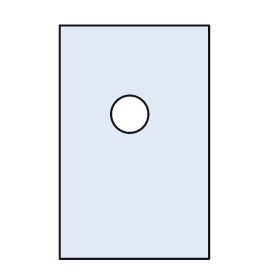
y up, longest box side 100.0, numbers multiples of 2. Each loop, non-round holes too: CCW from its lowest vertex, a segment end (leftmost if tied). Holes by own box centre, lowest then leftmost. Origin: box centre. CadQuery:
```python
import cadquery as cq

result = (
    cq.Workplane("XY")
    .moveTo(-32.0, -50.0)
    .lineTo(32.0, -50.0)
    .lineTo(32.0, 50.0)
    .lineTo(-32.0, 50.0)
    .close()
    .moveTo(-2.0, 12.0)
    .circle(8.0)
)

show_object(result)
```